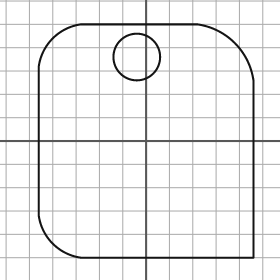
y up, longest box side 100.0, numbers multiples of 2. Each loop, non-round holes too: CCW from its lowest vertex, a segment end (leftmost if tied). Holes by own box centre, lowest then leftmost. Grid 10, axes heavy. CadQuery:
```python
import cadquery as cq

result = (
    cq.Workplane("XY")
    .moveTo(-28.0, -50.0)
    .lineTo(46.0, -50.0)
    .lineTo(46.0, 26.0)
    .threePointArc((38.0, 42.0), (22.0, 50.0))
    .lineTo(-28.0, 50.0)
    .threePointArc((-40.0, 44.0), (-46.0, 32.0))
    .lineTo(-46.0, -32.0)
    .threePointArc((-40.0, -44.0), (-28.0, -50.0))
    .close()
    .moveTo(-4.0, 36.0)
    .circle(10.0)
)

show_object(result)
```